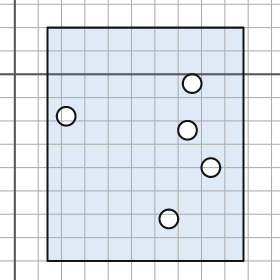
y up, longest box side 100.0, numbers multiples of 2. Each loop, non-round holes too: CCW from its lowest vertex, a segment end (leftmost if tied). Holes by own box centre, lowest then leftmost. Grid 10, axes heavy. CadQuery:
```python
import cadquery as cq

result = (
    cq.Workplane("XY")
    .moveTo(14.0, -80.0)
    .lineTo(98.0, -80.0)
    .lineTo(98.0, 20.0)
    .lineTo(14.0, 20.0)
    .close()
    .moveTo(66.0, -62.0)
    .circle(4.0)
    .moveTo(84.0, -40.0)
    .circle(4.0)
    .moveTo(74.0, -24.0)
    .circle(4.0)
    .moveTo(22.0, -18.0)
    .circle(4.0)
    .moveTo(76.0, -4.0)
    .circle(4.0)
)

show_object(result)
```